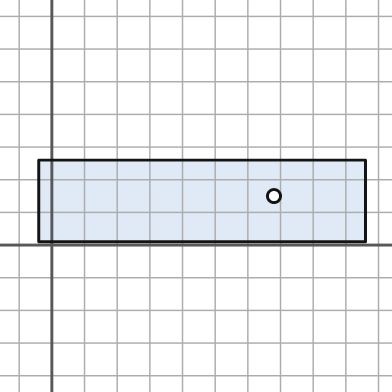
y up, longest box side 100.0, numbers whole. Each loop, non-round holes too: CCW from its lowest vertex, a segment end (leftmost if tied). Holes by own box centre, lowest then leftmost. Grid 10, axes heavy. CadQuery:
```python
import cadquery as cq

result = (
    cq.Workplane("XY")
    .moveTo(-4.0, 1.0)
    .lineTo(96.0, 1.0)
    .lineTo(96.0, 26.0)
    .lineTo(-4.0, 26.0)
    .close()
    .moveTo(68.0, 15.0)
    .circle(2.0)
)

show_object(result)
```